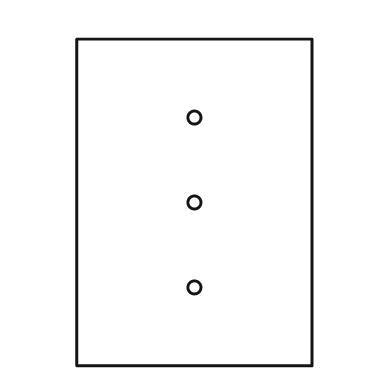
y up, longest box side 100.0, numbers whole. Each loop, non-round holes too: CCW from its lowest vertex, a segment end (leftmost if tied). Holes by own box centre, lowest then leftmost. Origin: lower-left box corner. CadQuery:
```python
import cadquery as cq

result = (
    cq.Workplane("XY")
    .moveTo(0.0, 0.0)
    .lineTo(72.0, 0.0)
    .lineTo(72.0, 100.0)
    .lineTo(0.0, 100.0)
    .close()
    .moveTo(36.0, 24.0)
    .circle(2.0)
    .moveTo(36.0, 50.0)
    .circle(2.0)
    .moveTo(36.0, 76.0)
    .circle(2.0)
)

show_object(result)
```